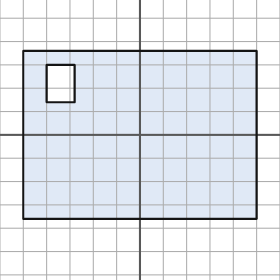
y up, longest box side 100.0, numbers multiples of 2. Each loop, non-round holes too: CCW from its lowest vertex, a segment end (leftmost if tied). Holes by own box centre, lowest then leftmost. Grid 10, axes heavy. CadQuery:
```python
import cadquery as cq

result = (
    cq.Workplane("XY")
    .moveTo(-50.0, -36.0)
    .lineTo(50.0, -36.0)
    .lineTo(50.0, 36.0)
    .lineTo(-50.0, 36.0)
    .close()
    .moveTo(-40.0, 14.0)
    .lineTo(-28.0, 14.0)
    .lineTo(-28.0, 30.0)
    .lineTo(-40.0, 30.0)
    .close()
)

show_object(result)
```